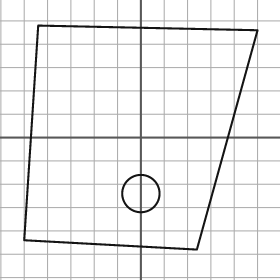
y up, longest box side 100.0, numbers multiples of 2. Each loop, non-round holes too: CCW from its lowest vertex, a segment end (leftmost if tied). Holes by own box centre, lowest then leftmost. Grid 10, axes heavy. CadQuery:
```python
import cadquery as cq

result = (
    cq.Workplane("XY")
    .moveTo(24.0, -48.0)
    .lineTo(50.0, 46.0)
    .lineTo(-44.0, 48.0)
    .lineTo(-50.0, -44.0)
    .close()
    .moveTo(0.0, -24.0)
    .circle(8.0)
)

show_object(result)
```